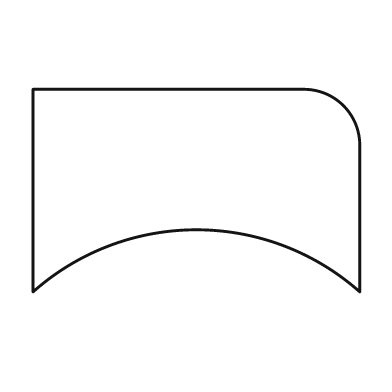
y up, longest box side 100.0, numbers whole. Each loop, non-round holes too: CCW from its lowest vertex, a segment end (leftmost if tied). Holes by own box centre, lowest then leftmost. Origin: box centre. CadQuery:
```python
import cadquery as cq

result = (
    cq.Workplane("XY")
    .moveTo(-50.0, -31.0)
    .threePointArc((0.0, -12.0), (50.0, -31.0))
    .lineTo(50.0, 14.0)
    .threePointArc((45.0, 26.0), (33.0, 31.0))
    .lineTo(-50.0, 31.0)
    .close()
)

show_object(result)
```